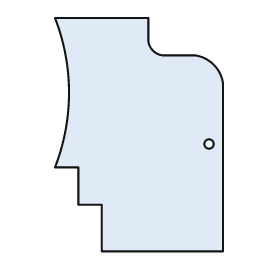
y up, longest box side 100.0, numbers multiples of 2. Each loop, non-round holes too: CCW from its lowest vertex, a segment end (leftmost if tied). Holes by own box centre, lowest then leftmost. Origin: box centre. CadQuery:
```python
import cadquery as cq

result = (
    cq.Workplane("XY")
    .moveTo(-16.0, -50.0)
    .lineTo(36.0, -50.0)
    .lineTo(36.0, 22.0)
    .threePointArc((32.0, 30.0), (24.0, 34.0))
    .lineTo(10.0, 34.0)
    .threePointArc((6.0, 36.0), (4.0, 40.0))
    .lineTo(4.0, 50.0)
    .lineTo(-36.0, 50.0)
    .threePointArc((-30.0, 18.0), (-36.0, -14.0))
    .lineTo(-26.0, -14.0)
    .lineTo(-26.0, -30.0)
    .lineTo(-16.0, -30.0)
    .close()
    .moveTo(30.0, -4.0)
    .circle(2.0)
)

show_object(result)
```